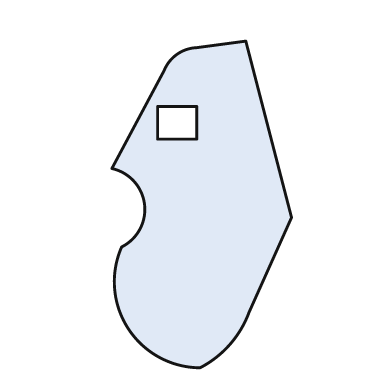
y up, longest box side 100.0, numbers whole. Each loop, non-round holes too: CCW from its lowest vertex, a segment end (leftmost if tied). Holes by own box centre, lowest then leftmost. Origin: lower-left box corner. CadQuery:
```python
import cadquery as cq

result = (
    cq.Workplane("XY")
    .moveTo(27.0, 0.0)
    .threePointArc((36.0, 7.0), (42.0, 17.0))
    .lineTo(55.0, 46.0)
    .lineTo(41.0, 100.0)
    .lineTo(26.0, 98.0)
    .threePointArc((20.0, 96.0), (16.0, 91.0))
    .lineTo(0.0, 61.0)
    .threePointArc((10.0, 50.0), (3.0, 37.0))
    .threePointArc((5.0, 12.0), (27.0, 0.0))
    .close()
    .moveTo(14.0, 70.0)
    .lineTo(26.0, 70.0)
    .lineTo(26.0, 80.0)
    .lineTo(14.0, 80.0)
    .close()
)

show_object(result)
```